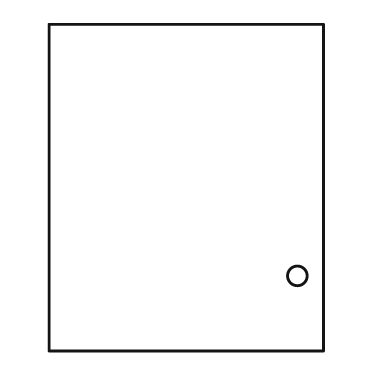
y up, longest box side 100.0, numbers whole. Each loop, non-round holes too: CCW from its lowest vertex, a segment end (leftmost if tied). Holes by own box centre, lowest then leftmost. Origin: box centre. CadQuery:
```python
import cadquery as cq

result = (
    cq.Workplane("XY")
    .moveTo(-42.0, -50.0)
    .lineTo(42.0, -50.0)
    .lineTo(42.0, 50.0)
    .lineTo(-42.0, 50.0)
    .close()
    .moveTo(34.0, -27.0)
    .circle(3.0)
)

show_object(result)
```